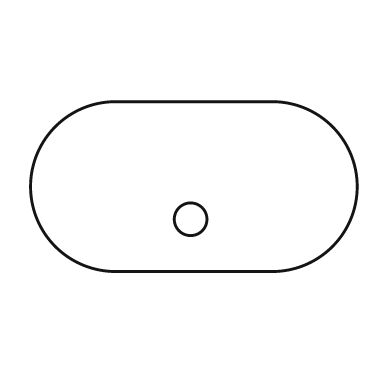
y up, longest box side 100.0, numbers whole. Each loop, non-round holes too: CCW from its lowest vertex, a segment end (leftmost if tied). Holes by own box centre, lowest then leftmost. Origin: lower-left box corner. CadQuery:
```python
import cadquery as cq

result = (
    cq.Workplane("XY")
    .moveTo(26.0, 0.0)
    .lineTo(74.0, 0.0)
    .threePointArc((100.0, 26.0), (74.0, 52.0))
    .lineTo(26.0, 52.0)
    .threePointArc((0.0, 26.0), (26.0, 0.0))
    .close()
    .moveTo(49.0, 16.0)
    .circle(5.0)
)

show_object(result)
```